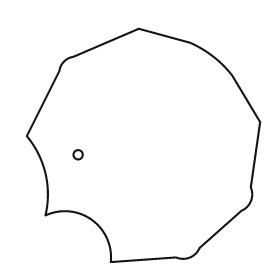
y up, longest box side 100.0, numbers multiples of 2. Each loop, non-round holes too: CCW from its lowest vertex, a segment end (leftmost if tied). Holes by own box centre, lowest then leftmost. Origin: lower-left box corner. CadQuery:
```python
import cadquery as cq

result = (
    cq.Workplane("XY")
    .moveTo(36.0, 0.0)
    .lineTo(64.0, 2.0)
    .threePointArc((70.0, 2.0), (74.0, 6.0))
    .lineTo(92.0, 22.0)
    .threePointArc((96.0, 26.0), (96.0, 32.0))
    .lineTo(100.0, 60.0)
    .lineTo(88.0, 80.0)
    .threePointArc((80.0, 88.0), (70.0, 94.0))
    .lineTo(48.0, 100.0)
    .lineTo(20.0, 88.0)
    .threePointArc((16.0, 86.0), (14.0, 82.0))
    .lineTo(0.0, 54.0)
    .threePointArc((8.0, 38.0), (8.0, 20.0))
    .threePointArc((28.0, 18.0), (36.0, 0.0))
    .close()
    .moveTo(22.0, 46.0)
    .circle(2.0)
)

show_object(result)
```